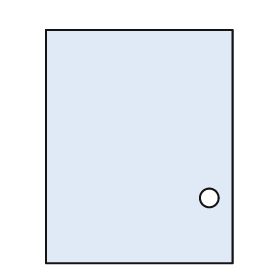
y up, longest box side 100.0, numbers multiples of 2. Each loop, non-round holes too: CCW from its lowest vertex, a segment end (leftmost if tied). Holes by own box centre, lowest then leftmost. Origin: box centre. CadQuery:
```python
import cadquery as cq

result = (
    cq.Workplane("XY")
    .moveTo(-40.0, -50.0)
    .lineTo(40.0, -50.0)
    .lineTo(40.0, 50.0)
    .lineTo(-40.0, 50.0)
    .close()
    .moveTo(30.0, -22.0)
    .circle(4.0)
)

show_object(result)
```